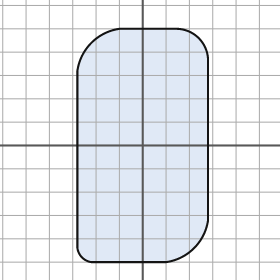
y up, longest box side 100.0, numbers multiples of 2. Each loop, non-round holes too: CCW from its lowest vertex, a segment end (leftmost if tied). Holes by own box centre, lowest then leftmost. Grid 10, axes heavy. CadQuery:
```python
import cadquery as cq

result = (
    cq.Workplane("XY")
    .moveTo(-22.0, -50.0)
    .lineTo(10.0, -50.0)
    .threePointArc((22.0, -44.0), (28.0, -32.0))
    .lineTo(28.0, 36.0)
    .threePointArc((24.0, 46.0), (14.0, 50.0))
    .lineTo(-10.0, 50.0)
    .threePointArc((-22.0, 44.0), (-28.0, 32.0))
    .lineTo(-28.0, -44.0)
    .threePointArc((-26.0, -48.0), (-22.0, -50.0))
    .close()
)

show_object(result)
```